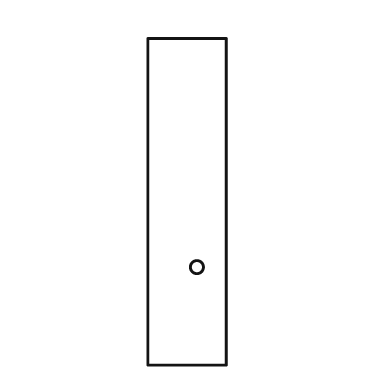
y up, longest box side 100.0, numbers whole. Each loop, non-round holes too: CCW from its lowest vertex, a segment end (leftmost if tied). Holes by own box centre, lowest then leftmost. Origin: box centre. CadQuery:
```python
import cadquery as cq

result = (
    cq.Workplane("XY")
    .moveTo(-12.0, -50.0)
    .lineTo(12.0, -50.0)
    .lineTo(12.0, 50.0)
    .lineTo(-12.0, 50.0)
    .close()
    .moveTo(3.0, -20.0)
    .circle(2.0)
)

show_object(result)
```